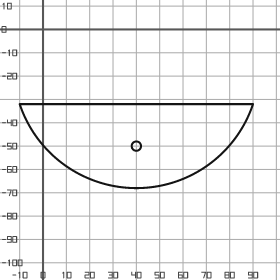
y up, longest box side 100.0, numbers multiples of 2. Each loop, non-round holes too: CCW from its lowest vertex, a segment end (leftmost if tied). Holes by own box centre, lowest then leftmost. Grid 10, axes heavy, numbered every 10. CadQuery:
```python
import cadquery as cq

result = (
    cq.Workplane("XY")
    .moveTo(-10.0, -32.0)
    .threePointArc((40.0, -68.0), (90.0, -32.0))
    .close()
    .moveTo(40.0, -50.0)
    .circle(2.0)
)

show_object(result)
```